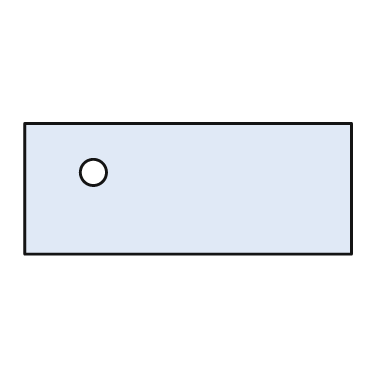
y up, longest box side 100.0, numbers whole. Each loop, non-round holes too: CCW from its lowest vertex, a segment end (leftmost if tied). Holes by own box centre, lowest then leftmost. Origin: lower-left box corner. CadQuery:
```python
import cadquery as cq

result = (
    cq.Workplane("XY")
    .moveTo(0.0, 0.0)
    .lineTo(100.0, 0.0)
    .lineTo(100.0, 40.0)
    .lineTo(0.0, 40.0)
    .close()
    .moveTo(21.0, 25.0)
    .circle(4.0)
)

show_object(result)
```